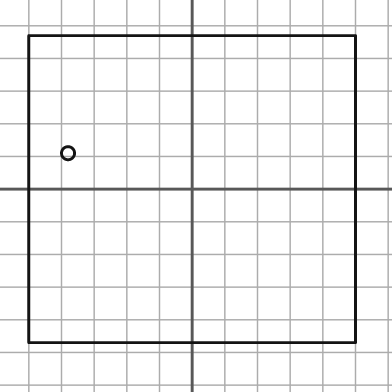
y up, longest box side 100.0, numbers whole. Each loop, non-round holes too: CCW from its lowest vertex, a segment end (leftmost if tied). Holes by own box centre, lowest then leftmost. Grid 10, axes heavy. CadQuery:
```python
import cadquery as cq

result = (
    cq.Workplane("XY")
    .moveTo(-50.0, -47.0)
    .lineTo(50.0, -47.0)
    .lineTo(50.0, 47.0)
    .lineTo(-50.0, 47.0)
    .close()
    .moveTo(-38.0, 11.0)
    .circle(2.0)
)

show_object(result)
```